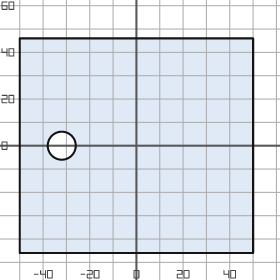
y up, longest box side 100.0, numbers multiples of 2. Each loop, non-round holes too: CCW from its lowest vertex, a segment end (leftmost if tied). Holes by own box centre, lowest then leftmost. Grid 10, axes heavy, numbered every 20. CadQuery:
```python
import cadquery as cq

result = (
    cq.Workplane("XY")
    .moveTo(-50.0, -46.0)
    .lineTo(50.0, -46.0)
    .lineTo(50.0, 46.0)
    .lineTo(-50.0, 46.0)
    .close()
    .moveTo(-32.0, 0.0)
    .circle(6.0)
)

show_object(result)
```